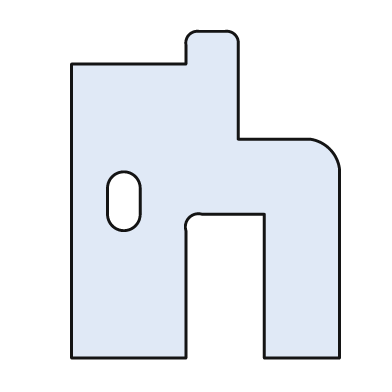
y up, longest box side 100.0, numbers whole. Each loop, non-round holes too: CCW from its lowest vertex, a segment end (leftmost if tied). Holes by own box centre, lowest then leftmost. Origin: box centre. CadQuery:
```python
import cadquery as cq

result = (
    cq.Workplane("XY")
    .moveTo(-41.0, -50.0)
    .lineTo(-6.0, -50.0)
    .lineTo(-6.0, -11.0)
    .threePointArc((-5.0, -7.0), (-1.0, -6.0))
    .lineTo(18.0, -6.0)
    .lineTo(18.0, -50.0)
    .lineTo(41.0, -50.0)
    .lineTo(41.0, 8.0)
    .threePointArc((38.0, 14.0), (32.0, 17.0))
    .lineTo(10.0, 17.0)
    .lineTo(10.0, 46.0)
    .threePointArc((9.0, 49.0), (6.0, 50.0))
    .lineTo(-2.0, 50.0)
    .threePointArc((-5.0, 49.0), (-6.0, 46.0))
    .lineTo(-6.0, 40.0)
    .lineTo(-41.0, 40.0)
    .close()
    .moveTo(-30.0, -6.0)
    .threePointArc((-25.0, -11.0), (-20.0, -6.0))
    .lineTo(-20.0, 2.0)
    .threePointArc((-25.0, 7.0), (-30.0, 2.0))
    .close()
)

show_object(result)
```